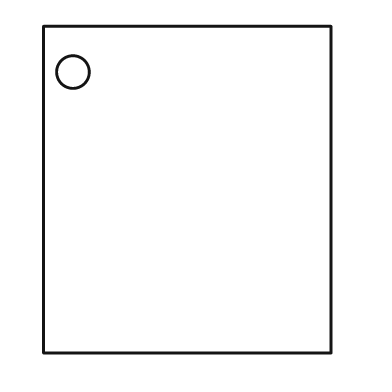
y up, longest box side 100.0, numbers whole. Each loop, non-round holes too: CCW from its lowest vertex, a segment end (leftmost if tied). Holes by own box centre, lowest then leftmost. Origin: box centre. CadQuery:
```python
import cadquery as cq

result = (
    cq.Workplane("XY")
    .moveTo(-44.0, -50.0)
    .lineTo(44.0, -50.0)
    .lineTo(44.0, 50.0)
    .lineTo(-44.0, 50.0)
    .close()
    .moveTo(-35.0, 36.0)
    .circle(5.0)
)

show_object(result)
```